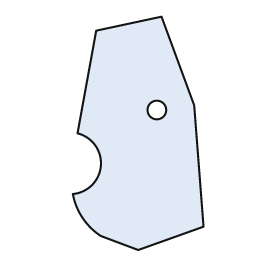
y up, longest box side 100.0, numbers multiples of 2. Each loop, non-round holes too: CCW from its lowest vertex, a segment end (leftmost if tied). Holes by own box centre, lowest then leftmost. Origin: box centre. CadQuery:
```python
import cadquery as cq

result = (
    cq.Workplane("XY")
    .moveTo(0.0, -50.0)
    .lineTo(28.0, -40.0)
    .lineTo(24.0, 12.0)
    .lineTo(10.0, 50.0)
    .lineTo(-18.0, 44.0)
    .lineTo(-26.0, 0.0)
    .threePointArc((-16.0, -14.0), (-28.0, -26.0))
    .threePointArc((-24.0, -36.0), (-16.0, -44.0))
    .close()
    .moveTo(8.0, 10.0)
    .circle(4.0)
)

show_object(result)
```